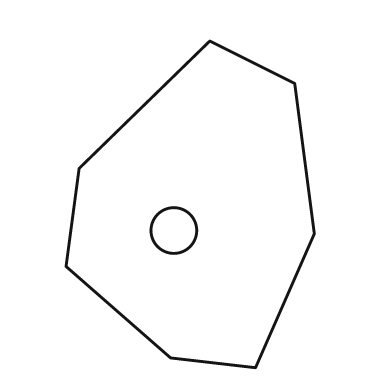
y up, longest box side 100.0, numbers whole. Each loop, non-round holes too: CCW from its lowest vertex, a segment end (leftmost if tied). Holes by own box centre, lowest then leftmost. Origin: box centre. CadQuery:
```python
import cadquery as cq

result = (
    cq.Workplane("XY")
    .moveTo(20.0, -50.0)
    .lineTo(38.0, -9.0)
    .lineTo(32.0, 37.0)
    .lineTo(6.0, 50.0)
    .lineTo(-34.0, 11.0)
    .lineTo(-38.0, -19.0)
    .lineTo(-6.0, -47.0)
    .close()
    .moveTo(-5.0, -8.0)
    .circle(7.0)
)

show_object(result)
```